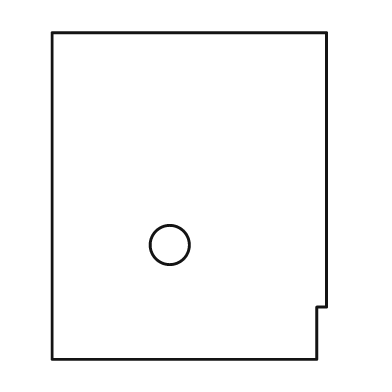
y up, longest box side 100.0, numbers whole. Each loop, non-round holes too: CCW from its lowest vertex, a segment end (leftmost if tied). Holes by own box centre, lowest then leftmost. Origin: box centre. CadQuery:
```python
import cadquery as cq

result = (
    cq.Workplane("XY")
    .moveTo(-42.0, -50.0)
    .lineTo(39.0, -50.0)
    .lineTo(39.0, -34.0)
    .lineTo(42.0, -34.0)
    .lineTo(42.0, 50.0)
    .lineTo(-42.0, 50.0)
    .close()
    .moveTo(-6.0, -15.0)
    .circle(6.0)
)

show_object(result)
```